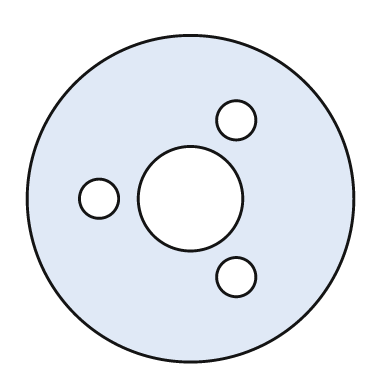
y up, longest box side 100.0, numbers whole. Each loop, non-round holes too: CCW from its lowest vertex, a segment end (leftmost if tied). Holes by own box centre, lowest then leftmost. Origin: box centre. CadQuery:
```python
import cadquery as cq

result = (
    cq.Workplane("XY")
    .moveTo(0.0, 0.0)
    .circle(50.0)
    .moveTo(14.0, -24.0)
    .circle(6.0)
    .moveTo(-28.0, 0.0)
    .circle(6.0)
    .moveTo(0.0, 0.0)
    .circle(16.0)
    .moveTo(14.0, 24.0)
    .circle(6.0)
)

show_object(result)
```